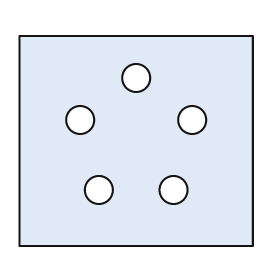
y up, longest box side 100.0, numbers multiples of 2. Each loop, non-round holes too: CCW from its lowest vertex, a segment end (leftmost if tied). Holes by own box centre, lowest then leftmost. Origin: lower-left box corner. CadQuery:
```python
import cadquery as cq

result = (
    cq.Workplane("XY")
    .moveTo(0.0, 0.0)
    .lineTo(100.0, 0.0)
    .lineTo(100.0, 90.0)
    .lineTo(0.0, 90.0)
    .close()
    .moveTo(34.0, 24.0)
    .circle(6.0)
    .moveTo(66.0, 24.0)
    .circle(6.0)
    .moveTo(26.0, 54.0)
    .circle(6.0)
    .moveTo(74.0, 54.0)
    .circle(6.0)
    .moveTo(50.0, 72.0)
    .circle(6.0)
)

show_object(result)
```